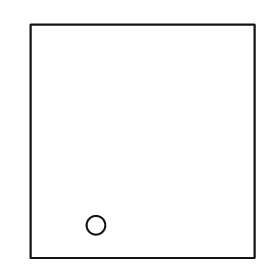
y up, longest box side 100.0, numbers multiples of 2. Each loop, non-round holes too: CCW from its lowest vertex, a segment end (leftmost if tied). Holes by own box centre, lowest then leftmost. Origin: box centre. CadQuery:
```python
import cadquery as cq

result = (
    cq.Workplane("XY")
    .moveTo(-48.0, -50.0)
    .lineTo(48.0, -50.0)
    .lineTo(48.0, 50.0)
    .lineTo(-48.0, 50.0)
    .close()
    .moveTo(-20.0, -36.0)
    .circle(4.0)
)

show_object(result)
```